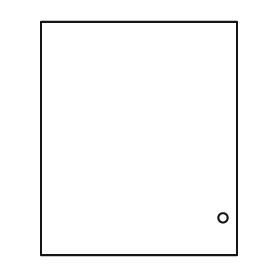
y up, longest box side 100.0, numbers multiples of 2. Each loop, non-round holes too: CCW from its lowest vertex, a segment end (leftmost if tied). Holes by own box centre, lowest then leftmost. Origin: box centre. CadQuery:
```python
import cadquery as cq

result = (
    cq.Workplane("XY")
    .moveTo(-42.0, -50.0)
    .lineTo(42.0, -50.0)
    .lineTo(42.0, 50.0)
    .lineTo(-42.0, 50.0)
    .close()
    .moveTo(36.0, -34.0)
    .circle(2.0)
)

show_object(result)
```